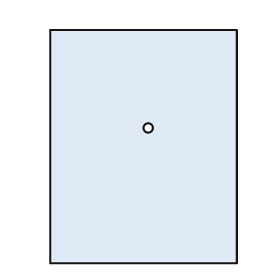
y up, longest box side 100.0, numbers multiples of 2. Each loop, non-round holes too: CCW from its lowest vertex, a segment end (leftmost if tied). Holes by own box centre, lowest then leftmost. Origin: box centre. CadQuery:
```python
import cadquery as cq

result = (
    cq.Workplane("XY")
    .moveTo(-40.0, -50.0)
    .lineTo(40.0, -50.0)
    .lineTo(40.0, 50.0)
    .lineTo(-40.0, 50.0)
    .close()
    .moveTo(2.0, 8.0)
    .circle(2.0)
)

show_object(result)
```